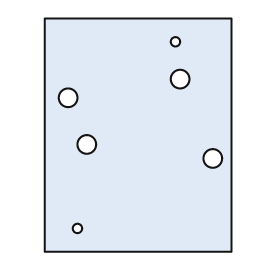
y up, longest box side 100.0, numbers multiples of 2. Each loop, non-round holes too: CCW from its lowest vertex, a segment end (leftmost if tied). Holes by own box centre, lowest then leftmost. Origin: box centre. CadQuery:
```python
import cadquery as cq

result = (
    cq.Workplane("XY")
    .moveTo(-40.0, -50.0)
    .lineTo(40.0, -50.0)
    .lineTo(40.0, 50.0)
    .lineTo(-40.0, 50.0)
    .close()
    .moveTo(-26.0, -40.0)
    .circle(2.0)
    .moveTo(32.0, -10.0)
    .circle(4.0)
    .moveTo(-22.0, -4.0)
    .circle(4.0)
    .moveTo(-30.0, 16.0)
    .circle(4.0)
    .moveTo(18.0, 24.0)
    .circle(4.0)
    .moveTo(16.0, 40.0)
    .circle(2.0)
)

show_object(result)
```